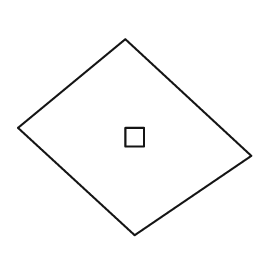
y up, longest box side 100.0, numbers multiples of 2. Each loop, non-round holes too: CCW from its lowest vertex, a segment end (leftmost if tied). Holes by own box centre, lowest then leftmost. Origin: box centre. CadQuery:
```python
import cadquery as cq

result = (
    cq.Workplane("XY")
    .moveTo(0.0, -42.0)
    .lineTo(50.0, -8.0)
    .lineTo(-4.0, 42.0)
    .lineTo(-50.0, 4.0)
    .close()
    .moveTo(-4.0, -4.0)
    .lineTo(4.0, -4.0)
    .lineTo(4.0, 4.0)
    .lineTo(-4.0, 4.0)
    .close()
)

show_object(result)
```